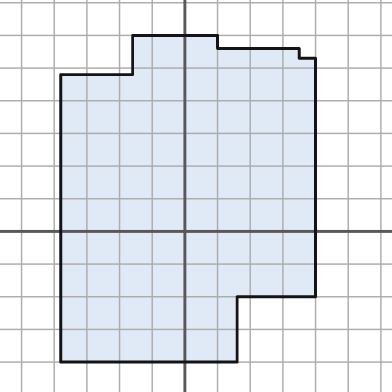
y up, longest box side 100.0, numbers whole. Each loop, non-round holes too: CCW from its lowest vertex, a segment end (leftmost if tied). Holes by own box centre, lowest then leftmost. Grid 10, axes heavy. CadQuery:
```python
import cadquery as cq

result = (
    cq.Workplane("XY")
    .moveTo(-38.0, -40.0)
    .lineTo(16.0, -40.0)
    .lineTo(16.0, -20.0)
    .lineTo(40.0, -20.0)
    .lineTo(40.0, 53.0)
    .lineTo(35.0, 53.0)
    .lineTo(35.0, 56.0)
    .lineTo(10.0, 56.0)
    .lineTo(10.0, 60.0)
    .lineTo(-16.0, 60.0)
    .lineTo(-16.0, 48.0)
    .lineTo(-38.0, 48.0)
    .close()
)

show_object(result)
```